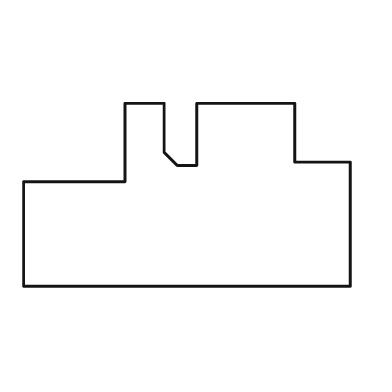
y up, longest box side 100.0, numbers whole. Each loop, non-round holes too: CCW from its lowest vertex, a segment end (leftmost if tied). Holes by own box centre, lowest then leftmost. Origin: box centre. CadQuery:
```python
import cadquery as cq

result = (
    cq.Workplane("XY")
    .moveTo(-50.0, -28.0)
    .lineTo(50.0, -28.0)
    .lineTo(50.0, 10.0)
    .lineTo(33.0, 10.0)
    .lineTo(33.0, 28.0)
    .lineTo(3.0, 28.0)
    .lineTo(3.0, 9.0)
    .lineTo(-3.0, 9.0)
    .lineTo(-7.0, 13.0)
    .lineTo(-7.0, 28.0)
    .lineTo(-19.0, 28.0)
    .lineTo(-19.0, 4.0)
    .lineTo(-50.0, 4.0)
    .close()
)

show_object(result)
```